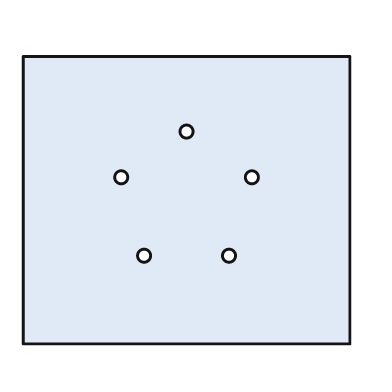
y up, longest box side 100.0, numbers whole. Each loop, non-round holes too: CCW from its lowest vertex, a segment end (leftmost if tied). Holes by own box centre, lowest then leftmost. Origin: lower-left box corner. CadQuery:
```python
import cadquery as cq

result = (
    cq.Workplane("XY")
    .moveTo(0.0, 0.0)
    .lineTo(100.0, 0.0)
    .lineTo(100.0, 88.0)
    .lineTo(0.0, 88.0)
    .close()
    .moveTo(37.0, 27.0)
    .circle(2.0)
    .moveTo(63.0, 27.0)
    .circle(2.0)
    .moveTo(30.0, 51.0)
    .circle(2.0)
    .moveTo(70.0, 51.0)
    .circle(2.0)
    .moveTo(50.0, 65.0)
    .circle(2.0)
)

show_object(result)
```